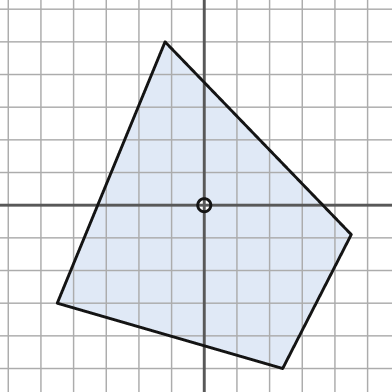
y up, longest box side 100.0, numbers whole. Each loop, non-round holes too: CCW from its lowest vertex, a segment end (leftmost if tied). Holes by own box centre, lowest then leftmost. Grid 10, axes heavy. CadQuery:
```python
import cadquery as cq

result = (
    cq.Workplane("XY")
    .moveTo(24.0, -50.0)
    .lineTo(45.0, -9.0)
    .lineTo(-12.0, 50.0)
    .lineTo(-45.0, -30.0)
    .close()
    .moveTo(0.0, 0.0)
    .circle(2.0)
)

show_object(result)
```